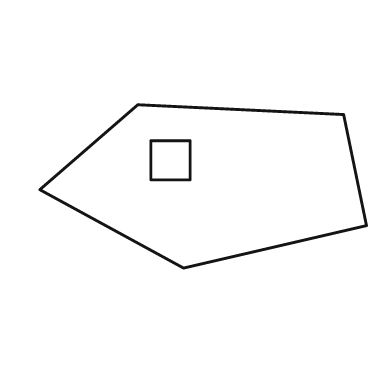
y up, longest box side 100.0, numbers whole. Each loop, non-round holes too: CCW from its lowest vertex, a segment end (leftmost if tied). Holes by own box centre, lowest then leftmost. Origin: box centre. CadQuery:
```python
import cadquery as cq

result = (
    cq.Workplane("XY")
    .moveTo(-6.0, -25.0)
    .lineTo(50.0, -12.0)
    .lineTo(43.0, 22.0)
    .lineTo(-20.0, 25.0)
    .lineTo(-50.0, -1.0)
    .close()
    .moveTo(-16.0, 2.0)
    .lineTo(-4.0, 2.0)
    .lineTo(-4.0, 14.0)
    .lineTo(-16.0, 14.0)
    .close()
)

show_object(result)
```